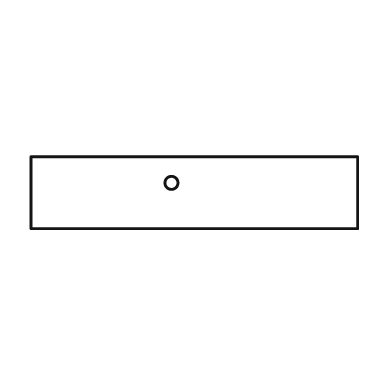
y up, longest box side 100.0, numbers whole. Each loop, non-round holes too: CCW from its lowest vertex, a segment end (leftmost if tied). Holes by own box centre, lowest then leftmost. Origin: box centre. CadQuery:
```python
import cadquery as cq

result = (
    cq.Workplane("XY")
    .moveTo(-50.0, -11.0)
    .lineTo(50.0, -11.0)
    .lineTo(50.0, 11.0)
    .lineTo(-50.0, 11.0)
    .close()
    .moveTo(-7.0, 3.0)
    .circle(2.0)
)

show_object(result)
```